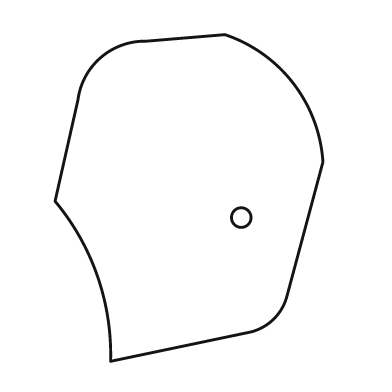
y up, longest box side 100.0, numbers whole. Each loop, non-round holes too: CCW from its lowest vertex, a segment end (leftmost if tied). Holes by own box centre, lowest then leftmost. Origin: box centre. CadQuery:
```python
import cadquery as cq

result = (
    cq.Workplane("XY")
    .moveTo(-24.0, -50.0)
    .lineTo(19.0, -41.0)
    .threePointArc((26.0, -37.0), (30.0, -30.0))
    .lineTo(41.0, 11.0)
    .threePointArc((32.0, 35.0), (11.0, 50.0))
    .lineTo(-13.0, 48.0)
    .threePointArc((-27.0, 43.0), (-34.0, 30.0))
    .lineTo(-41.0, -1.0)
    .threePointArc((-28.0, -24.0), (-24.0, -50.0))
    .close()
    .moveTo(16.0, -6.0)
    .circle(3.0)
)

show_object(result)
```